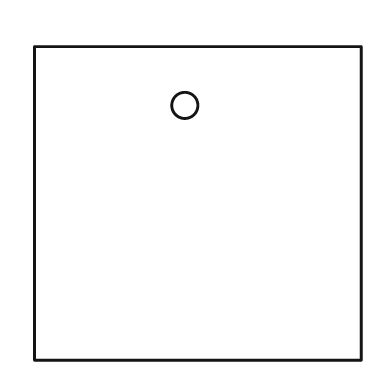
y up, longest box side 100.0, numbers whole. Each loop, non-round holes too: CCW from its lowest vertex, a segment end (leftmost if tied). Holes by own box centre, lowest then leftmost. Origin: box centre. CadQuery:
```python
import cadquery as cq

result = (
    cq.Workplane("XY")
    .moveTo(-50.0, -48.0)
    .lineTo(50.0, -48.0)
    .lineTo(50.0, 48.0)
    .lineTo(-50.0, 48.0)
    .close()
    .moveTo(-4.0, 30.0)
    .circle(4.0)
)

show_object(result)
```